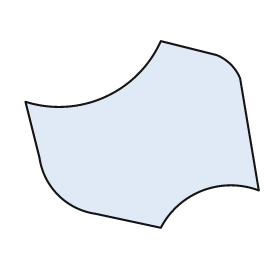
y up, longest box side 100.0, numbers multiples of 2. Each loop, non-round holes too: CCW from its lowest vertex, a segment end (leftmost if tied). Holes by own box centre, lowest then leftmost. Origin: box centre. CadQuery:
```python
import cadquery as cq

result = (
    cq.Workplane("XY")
    .moveTo(8.0, -40.0)
    .threePointArc((26.0, -24.0), (50.0, -24.0))
    .lineTo(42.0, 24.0)
    .threePointArc((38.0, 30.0), (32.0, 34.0))
    .lineTo(8.0, 40.0)
    .threePointArc((-16.0, 16.0), (-50.0, 14.0))
    .lineTo(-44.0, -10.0)
    .threePointArc((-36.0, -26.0), (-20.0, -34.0))
    .close()
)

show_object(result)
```